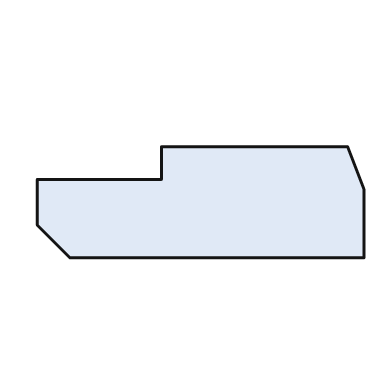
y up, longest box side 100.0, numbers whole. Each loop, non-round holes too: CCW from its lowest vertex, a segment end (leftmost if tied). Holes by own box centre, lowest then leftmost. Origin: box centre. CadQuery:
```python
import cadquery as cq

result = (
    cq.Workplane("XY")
    .moveTo(-40.0, -17.0)
    .lineTo(50.0, -17.0)
    .lineTo(50.0, 4.0)
    .lineTo(45.0, 17.0)
    .lineTo(-12.0, 17.0)
    .lineTo(-12.0, 7.0)
    .lineTo(-50.0, 7.0)
    .lineTo(-50.0, -7.0)
    .close()
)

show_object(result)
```